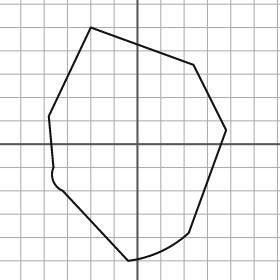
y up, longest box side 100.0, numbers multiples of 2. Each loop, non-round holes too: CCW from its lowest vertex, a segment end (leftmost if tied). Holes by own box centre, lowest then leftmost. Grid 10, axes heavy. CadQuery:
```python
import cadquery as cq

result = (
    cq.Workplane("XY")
    .moveTo(-4.0, -50.0)
    .threePointArc((10.0, -46.0), (22.0, -38.0))
    .lineTo(38.0, 6.0)
    .lineTo(24.0, 34.0)
    .lineTo(-20.0, 50.0)
    .lineTo(-38.0, 12.0)
    .lineTo(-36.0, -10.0)
    .threePointArc((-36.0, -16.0), (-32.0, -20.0))
    .close()
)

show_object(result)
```